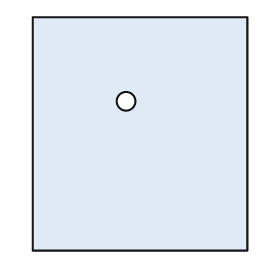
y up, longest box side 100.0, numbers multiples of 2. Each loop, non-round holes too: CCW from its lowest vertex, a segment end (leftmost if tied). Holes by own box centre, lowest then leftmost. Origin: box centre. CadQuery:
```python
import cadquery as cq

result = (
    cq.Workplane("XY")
    .moveTo(-46.0, -50.0)
    .lineTo(46.0, -50.0)
    .lineTo(46.0, 50.0)
    .lineTo(-46.0, 50.0)
    .close()
    .moveTo(-6.0, 14.0)
    .circle(4.0)
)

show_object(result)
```